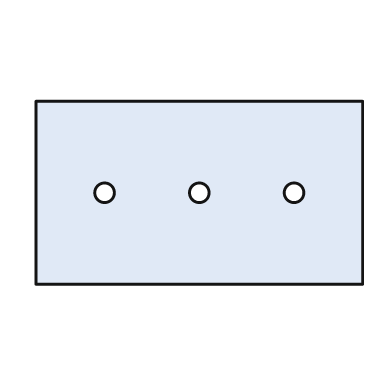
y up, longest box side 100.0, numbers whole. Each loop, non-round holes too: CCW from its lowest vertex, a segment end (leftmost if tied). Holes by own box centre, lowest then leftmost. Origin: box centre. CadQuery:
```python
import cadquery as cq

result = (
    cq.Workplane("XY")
    .moveTo(-50.0, -28.0)
    .lineTo(50.0, -28.0)
    .lineTo(50.0, 28.0)
    .lineTo(-50.0, 28.0)
    .close()
    .moveTo(-29.0, 0.0)
    .circle(3.0)
    .moveTo(0.0, 0.0)
    .circle(3.0)
    .moveTo(29.0, 0.0)
    .circle(3.0)
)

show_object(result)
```